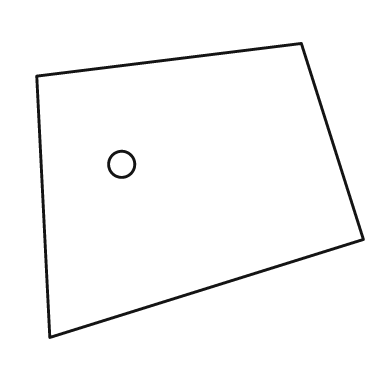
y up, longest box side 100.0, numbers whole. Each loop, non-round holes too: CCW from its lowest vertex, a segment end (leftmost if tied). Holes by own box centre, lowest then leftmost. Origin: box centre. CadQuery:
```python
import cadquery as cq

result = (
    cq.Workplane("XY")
    .moveTo(-46.0, -45.0)
    .lineTo(50.0, -15.0)
    .lineTo(31.0, 45.0)
    .lineTo(-50.0, 35.0)
    .close()
    .moveTo(-24.0, 8.0)
    .circle(4.0)
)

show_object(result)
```